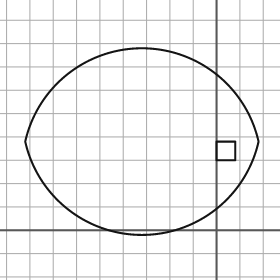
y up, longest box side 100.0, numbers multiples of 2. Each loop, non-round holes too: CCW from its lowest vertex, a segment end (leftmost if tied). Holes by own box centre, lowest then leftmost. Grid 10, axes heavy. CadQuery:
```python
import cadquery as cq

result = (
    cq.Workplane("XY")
    .moveTo(-82.0, 38.0)
    .threePointArc((-32.0, -2.0), (18.0, 38.0))
    .threePointArc((-32.0, 78.0), (-82.0, 38.0))
    .close()
    .moveTo(0.0, 30.0)
    .lineTo(8.0, 30.0)
    .lineTo(8.0, 38.0)
    .lineTo(0.0, 38.0)
    .close()
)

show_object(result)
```